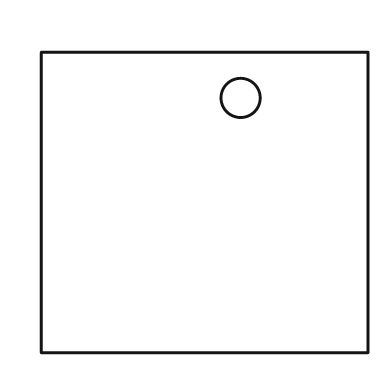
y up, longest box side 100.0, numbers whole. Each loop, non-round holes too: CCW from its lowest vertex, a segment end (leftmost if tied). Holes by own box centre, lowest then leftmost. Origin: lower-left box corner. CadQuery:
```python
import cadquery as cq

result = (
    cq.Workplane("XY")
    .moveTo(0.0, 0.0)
    .lineTo(100.0, 0.0)
    .lineTo(100.0, 92.0)
    .lineTo(0.0, 92.0)
    .close()
    .moveTo(61.0, 78.0)
    .circle(6.0)
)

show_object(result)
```